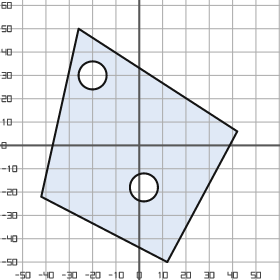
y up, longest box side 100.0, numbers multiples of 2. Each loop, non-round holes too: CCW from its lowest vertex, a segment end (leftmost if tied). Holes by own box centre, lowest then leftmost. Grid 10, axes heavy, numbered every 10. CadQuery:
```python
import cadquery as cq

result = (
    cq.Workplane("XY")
    .moveTo(12.0, -50.0)
    .lineTo(42.0, 6.0)
    .lineTo(-26.0, 50.0)
    .lineTo(-42.0, -22.0)
    .close()
    .moveTo(2.0, -18.0)
    .circle(6.0)
    .moveTo(-20.0, 30.0)
    .circle(6.0)
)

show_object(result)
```